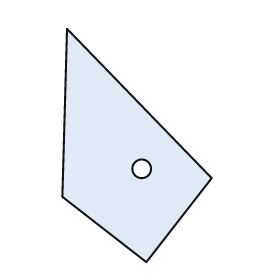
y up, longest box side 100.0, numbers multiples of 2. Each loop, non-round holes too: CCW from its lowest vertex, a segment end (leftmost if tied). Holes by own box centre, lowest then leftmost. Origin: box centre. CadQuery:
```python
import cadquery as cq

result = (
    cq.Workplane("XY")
    .moveTo(4.0, -50.0)
    .lineTo(32.0, -14.0)
    .lineTo(-30.0, 50.0)
    .lineTo(-32.0, -22.0)
    .close()
    .moveTo(2.0, -10.0)
    .circle(4.0)
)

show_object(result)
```